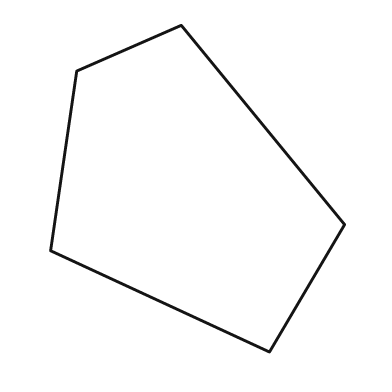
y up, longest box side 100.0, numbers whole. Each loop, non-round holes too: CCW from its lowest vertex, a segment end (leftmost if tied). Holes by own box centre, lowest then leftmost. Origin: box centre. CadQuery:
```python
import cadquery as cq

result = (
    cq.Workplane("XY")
    .moveTo(22.0, -50.0)
    .lineTo(45.0, -11.0)
    .lineTo(-5.0, 50.0)
    .lineTo(-37.0, 36.0)
    .lineTo(-45.0, -19.0)
    .close()
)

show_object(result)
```